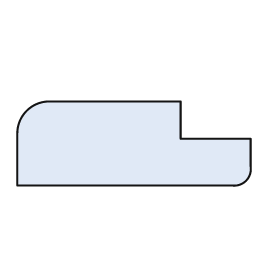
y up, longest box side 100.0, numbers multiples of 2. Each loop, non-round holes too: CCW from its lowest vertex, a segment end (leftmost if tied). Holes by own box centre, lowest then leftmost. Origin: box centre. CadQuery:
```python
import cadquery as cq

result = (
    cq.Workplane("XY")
    .moveTo(-50.0, -18.0)
    .lineTo(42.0, -18.0)
    .threePointArc((48.0, -16.0), (50.0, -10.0))
    .lineTo(50.0, 2.0)
    .lineTo(20.0, 2.0)
    .lineTo(20.0, 18.0)
    .lineTo(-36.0, 18.0)
    .threePointArc((-46.0, 14.0), (-50.0, 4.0))
    .close()
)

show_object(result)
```